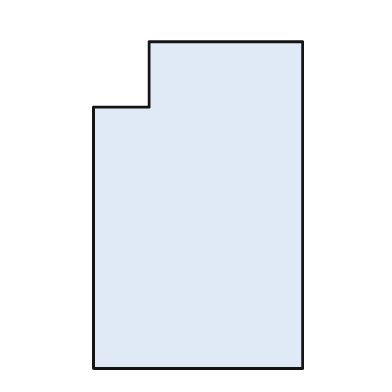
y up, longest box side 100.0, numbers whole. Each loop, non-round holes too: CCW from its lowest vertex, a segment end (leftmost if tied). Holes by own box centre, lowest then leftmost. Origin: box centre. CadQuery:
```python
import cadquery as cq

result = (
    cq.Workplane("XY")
    .moveTo(-32.0, -50.0)
    .lineTo(32.0, -50.0)
    .lineTo(32.0, 50.0)
    .lineTo(-15.0, 50.0)
    .lineTo(-15.0, 30.0)
    .lineTo(-32.0, 30.0)
    .close()
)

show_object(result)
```